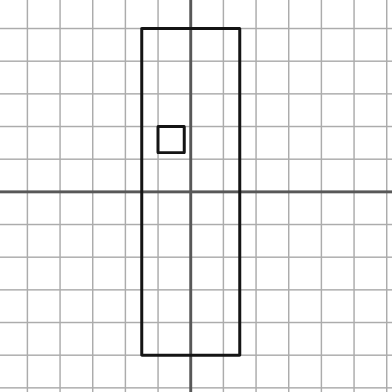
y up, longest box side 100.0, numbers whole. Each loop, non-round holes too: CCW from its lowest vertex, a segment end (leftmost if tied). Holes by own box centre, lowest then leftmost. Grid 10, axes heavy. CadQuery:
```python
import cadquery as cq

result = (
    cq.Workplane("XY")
    .moveTo(-15.0, -50.0)
    .lineTo(15.0, -50.0)
    .lineTo(15.0, 50.0)
    .lineTo(-15.0, 50.0)
    .close()
    .moveTo(-10.0, 12.0)
    .lineTo(-2.0, 12.0)
    .lineTo(-2.0, 20.0)
    .lineTo(-10.0, 20.0)
    .close()
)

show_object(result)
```